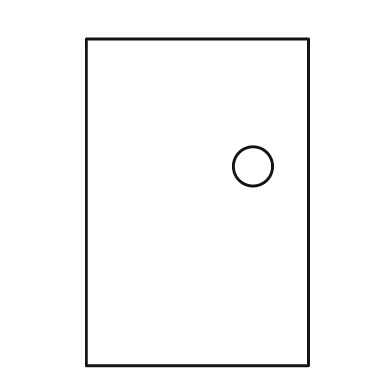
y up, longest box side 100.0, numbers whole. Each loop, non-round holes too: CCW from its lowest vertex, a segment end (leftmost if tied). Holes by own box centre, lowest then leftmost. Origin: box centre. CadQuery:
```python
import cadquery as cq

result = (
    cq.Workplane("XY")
    .moveTo(-34.0, -50.0)
    .lineTo(34.0, -50.0)
    .lineTo(34.0, 50.0)
    .lineTo(-34.0, 50.0)
    .close()
    .moveTo(17.0, 11.0)
    .circle(6.0)
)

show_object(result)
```